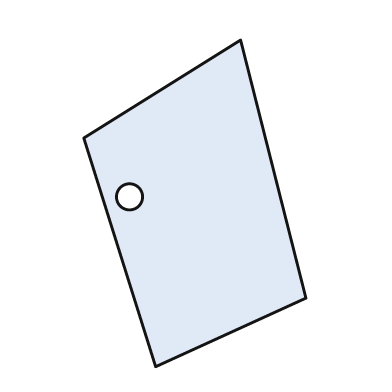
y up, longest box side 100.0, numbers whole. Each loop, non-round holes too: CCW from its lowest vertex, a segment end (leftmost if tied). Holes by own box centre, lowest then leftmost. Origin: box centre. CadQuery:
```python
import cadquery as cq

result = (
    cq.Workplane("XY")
    .moveTo(-12.0, -50.0)
    .lineTo(34.0, -29.0)
    .lineTo(14.0, 50.0)
    .lineTo(-34.0, 20.0)
    .close()
    .moveTo(-20.0, 2.0)
    .circle(4.0)
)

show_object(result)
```